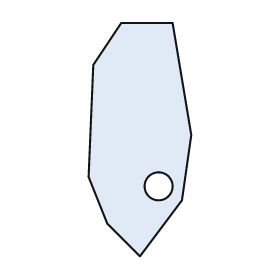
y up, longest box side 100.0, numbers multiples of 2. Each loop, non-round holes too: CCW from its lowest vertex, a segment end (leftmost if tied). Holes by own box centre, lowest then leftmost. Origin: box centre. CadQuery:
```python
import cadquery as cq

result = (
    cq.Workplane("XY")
    .moveTo(0.0, -50.0)
    .lineTo(18.0, -26.0)
    .lineTo(22.0, 2.0)
    .lineTo(14.0, 50.0)
    .lineTo(-8.0, 50.0)
    .lineTo(-20.0, 32.0)
    .lineTo(-22.0, -16.0)
    .lineTo(-14.0, -36.0)
    .close()
    .moveTo(8.0, -20.0)
    .circle(6.0)
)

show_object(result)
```